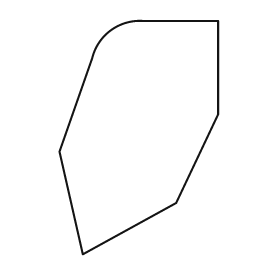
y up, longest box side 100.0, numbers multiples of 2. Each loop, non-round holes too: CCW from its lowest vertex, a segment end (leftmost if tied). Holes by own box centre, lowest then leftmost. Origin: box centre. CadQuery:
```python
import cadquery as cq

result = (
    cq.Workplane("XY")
    .moveTo(-24.0, -50.0)
    .lineTo(16.0, -28.0)
    .lineTo(34.0, 10.0)
    .lineTo(34.0, 50.0)
    .lineTo(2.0, 50.0)
    .threePointArc((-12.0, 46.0), (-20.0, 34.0))
    .lineTo(-34.0, -6.0)
    .close()
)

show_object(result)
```